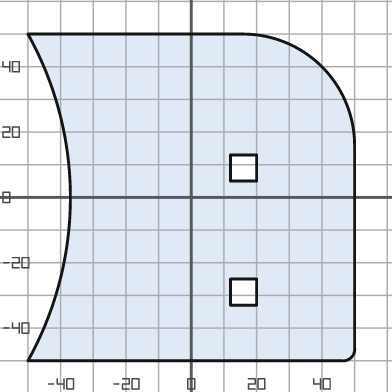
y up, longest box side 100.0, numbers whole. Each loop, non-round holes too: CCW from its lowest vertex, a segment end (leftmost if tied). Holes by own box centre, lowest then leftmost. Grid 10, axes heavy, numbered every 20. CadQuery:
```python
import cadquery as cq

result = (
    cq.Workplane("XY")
    .moveTo(-50.0, -50.0)
    .lineTo(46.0, -50.0)
    .threePointArc((49.0, -49.0), (50.0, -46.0))
    .lineTo(50.0, 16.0)
    .threePointArc((40.0, 40.0), (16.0, 50.0))
    .lineTo(-50.0, 50.0)
    .threePointArc((-37.0, 0.0), (-50.0, -50.0))
    .close()
    .moveTo(12.0, -33.0)
    .lineTo(20.0, -33.0)
    .lineTo(20.0, -25.0)
    .lineTo(12.0, -25.0)
    .close()
    .moveTo(12.0, 5.0)
    .lineTo(20.0, 5.0)
    .lineTo(20.0, 13.0)
    .lineTo(12.0, 13.0)
    .close()
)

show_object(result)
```